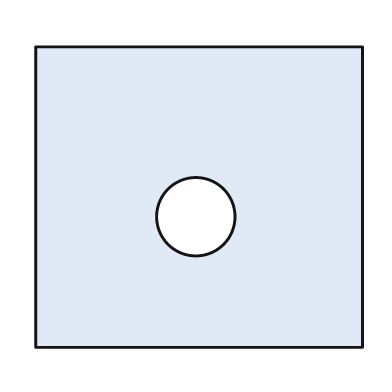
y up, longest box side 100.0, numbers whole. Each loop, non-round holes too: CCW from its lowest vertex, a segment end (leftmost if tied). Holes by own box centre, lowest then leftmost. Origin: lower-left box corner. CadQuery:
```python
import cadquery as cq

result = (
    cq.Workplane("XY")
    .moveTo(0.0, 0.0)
    .lineTo(100.0, 0.0)
    .lineTo(100.0, 92.0)
    .lineTo(0.0, 92.0)
    .close()
    .moveTo(49.0, 40.0)
    .circle(12.0)
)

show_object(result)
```